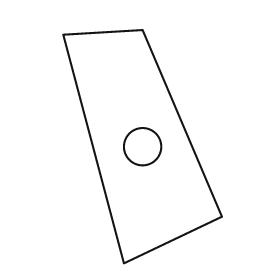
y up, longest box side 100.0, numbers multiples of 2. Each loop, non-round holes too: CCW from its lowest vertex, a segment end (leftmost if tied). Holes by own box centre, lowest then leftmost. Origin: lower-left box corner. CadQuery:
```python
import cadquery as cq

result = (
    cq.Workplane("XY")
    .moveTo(26.0, 0.0)
    .lineTo(68.0, 20.0)
    .lineTo(34.0, 100.0)
    .lineTo(0.0, 98.0)
    .close()
    .moveTo(34.0, 50.0)
    .circle(8.0)
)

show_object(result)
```